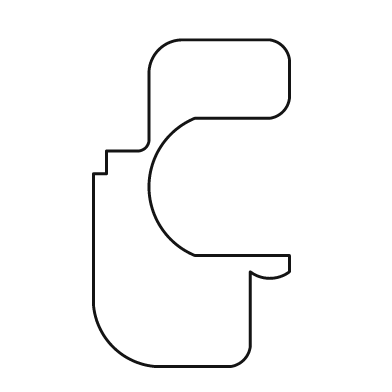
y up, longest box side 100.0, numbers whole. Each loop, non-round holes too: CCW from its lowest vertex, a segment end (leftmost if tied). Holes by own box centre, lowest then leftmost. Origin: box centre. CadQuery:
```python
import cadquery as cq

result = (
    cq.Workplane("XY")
    .moveTo(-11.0, -50.0)
    .lineTo(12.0, -50.0)
    .threePointArc((16.0, -48.0), (18.0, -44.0))
    .lineTo(18.0, -21.0)
    .threePointArc((24.0, -23.0), (30.0, -21.0))
    .lineTo(30.0, -16.0)
    .lineTo(1.0, -16.0)
    .threePointArc((-13.0, 5.0), (1.0, 26.0))
    .lineTo(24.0, 26.0)
    .threePointArc((28.0, 28.0), (30.0, 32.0))
    .lineTo(30.0, 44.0)
    .threePointArc((28.0, 48.0), (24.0, 50.0))
    .lineTo(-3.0, 50.0)
    .threePointArc((-10.0, 47.0), (-13.0, 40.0))
    .lineTo(-13.0, 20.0)
    .threePointArc((-14.0, 17.0), (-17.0, 16.0))
    .lineTo(-26.0, 16.0)
    .lineTo(-26.0, 9.0)
    .lineTo(-30.0, 9.0)
    .lineTo(-30.0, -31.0)
    .threePointArc((-24.0, -44.0), (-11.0, -50.0))
    .close()
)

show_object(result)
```